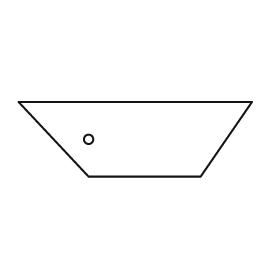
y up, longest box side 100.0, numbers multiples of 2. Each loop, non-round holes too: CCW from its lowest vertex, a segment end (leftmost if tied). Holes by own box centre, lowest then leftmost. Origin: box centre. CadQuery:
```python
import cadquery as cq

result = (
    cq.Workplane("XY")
    .moveTo(-20.0, -16.0)
    .lineTo(28.0, -16.0)
    .lineTo(50.0, 16.0)
    .lineTo(-50.0, 16.0)
    .close()
    .moveTo(-20.0, 0.0)
    .circle(2.0)
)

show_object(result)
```